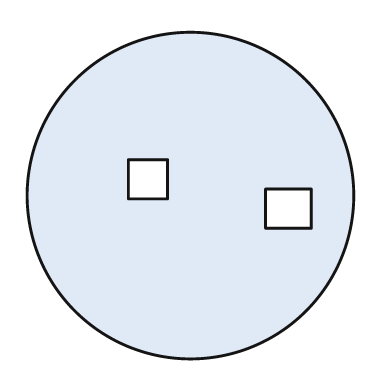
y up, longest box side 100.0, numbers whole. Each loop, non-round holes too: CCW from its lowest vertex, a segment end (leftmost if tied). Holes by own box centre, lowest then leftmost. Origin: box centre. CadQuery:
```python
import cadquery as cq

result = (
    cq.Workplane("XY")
    .moveTo(0.0, 0.0)
    .circle(50.0)
    .moveTo(23.0, -10.0)
    .lineTo(37.0, -10.0)
    .lineTo(37.0, 2.0)
    .lineTo(23.0, 2.0)
    .close()
    .moveTo(-19.0, -1.0)
    .lineTo(-7.0, -1.0)
    .lineTo(-7.0, 11.0)
    .lineTo(-19.0, 11.0)
    .close()
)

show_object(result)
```